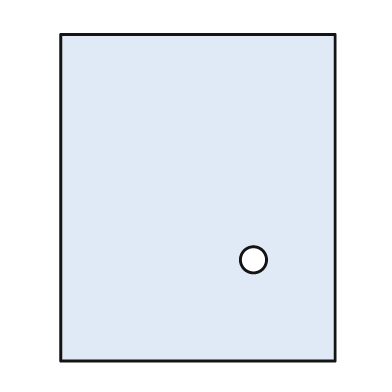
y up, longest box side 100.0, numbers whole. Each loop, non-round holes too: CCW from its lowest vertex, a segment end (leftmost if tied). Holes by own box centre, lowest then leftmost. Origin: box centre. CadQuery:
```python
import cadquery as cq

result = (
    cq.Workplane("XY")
    .moveTo(-42.0, -50.0)
    .lineTo(42.0, -50.0)
    .lineTo(42.0, 50.0)
    .lineTo(-42.0, 50.0)
    .close()
    .moveTo(17.0, -19.0)
    .circle(4.0)
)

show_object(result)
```